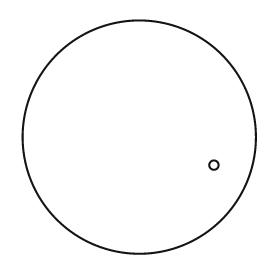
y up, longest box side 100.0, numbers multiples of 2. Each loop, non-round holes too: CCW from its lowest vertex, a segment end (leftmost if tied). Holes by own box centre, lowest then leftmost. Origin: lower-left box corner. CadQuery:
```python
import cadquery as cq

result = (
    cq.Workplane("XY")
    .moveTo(50.0, 50.0)
    .circle(50.0)
    .moveTo(82.0, 38.0)
    .circle(2.0)
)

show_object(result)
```